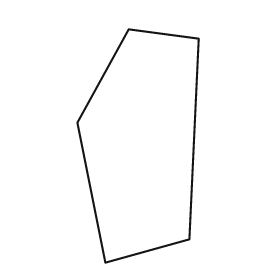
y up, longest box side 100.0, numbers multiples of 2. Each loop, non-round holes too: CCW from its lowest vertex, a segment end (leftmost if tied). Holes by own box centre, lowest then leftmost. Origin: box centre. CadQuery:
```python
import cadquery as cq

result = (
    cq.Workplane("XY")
    .moveTo(-14.0, -50.0)
    .lineTo(22.0, -40.0)
    .lineTo(26.0, 46.0)
    .lineTo(-4.0, 50.0)
    .lineTo(-26.0, 10.0)
    .close()
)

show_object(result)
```